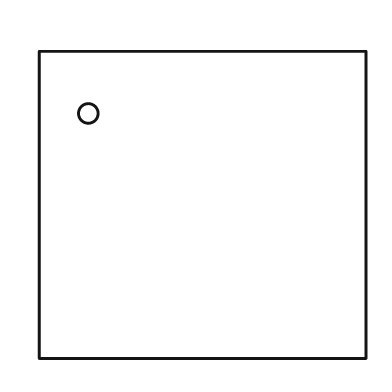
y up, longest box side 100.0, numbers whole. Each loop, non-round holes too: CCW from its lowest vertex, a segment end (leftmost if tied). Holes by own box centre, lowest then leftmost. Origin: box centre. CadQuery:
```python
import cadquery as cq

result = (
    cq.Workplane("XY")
    .moveTo(-50.0, -47.0)
    .lineTo(50.0, -47.0)
    .lineTo(50.0, 47.0)
    .lineTo(-50.0, 47.0)
    .close()
    .moveTo(-35.0, 28.0)
    .circle(3.0)
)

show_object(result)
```